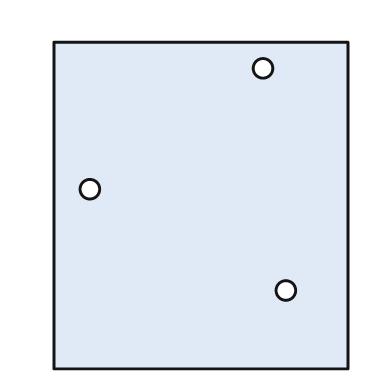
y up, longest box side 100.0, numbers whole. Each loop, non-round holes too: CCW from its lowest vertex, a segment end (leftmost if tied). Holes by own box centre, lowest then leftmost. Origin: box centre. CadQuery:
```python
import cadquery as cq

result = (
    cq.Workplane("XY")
    .moveTo(-45.0, -50.0)
    .lineTo(45.0, -50.0)
    .lineTo(45.0, 50.0)
    .lineTo(-45.0, 50.0)
    .close()
    .moveTo(26.0, -26.0)
    .circle(3.0)
    .moveTo(-34.0, 5.0)
    .circle(3.0)
    .moveTo(19.0, 42.0)
    .circle(3.0)
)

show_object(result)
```